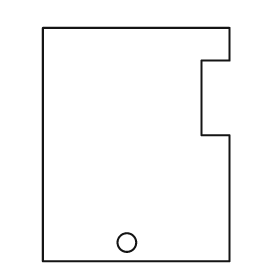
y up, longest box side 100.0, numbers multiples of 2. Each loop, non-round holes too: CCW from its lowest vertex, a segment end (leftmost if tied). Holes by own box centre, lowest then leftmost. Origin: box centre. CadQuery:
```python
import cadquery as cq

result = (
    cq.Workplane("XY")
    .moveTo(-40.0, -50.0)
    .lineTo(40.0, -50.0)
    .lineTo(40.0, 4.0)
    .lineTo(28.0, 4.0)
    .lineTo(28.0, 36.0)
    .lineTo(40.0, 36.0)
    .lineTo(40.0, 50.0)
    .lineTo(-40.0, 50.0)
    .close()
    .moveTo(-4.0, -42.0)
    .circle(4.0)
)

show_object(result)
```